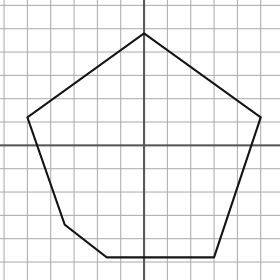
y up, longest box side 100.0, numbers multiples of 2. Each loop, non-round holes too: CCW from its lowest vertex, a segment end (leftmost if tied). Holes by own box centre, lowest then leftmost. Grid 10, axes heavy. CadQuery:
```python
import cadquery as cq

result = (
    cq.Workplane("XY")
    .moveTo(-16.0, -48.0)
    .lineTo(30.0, -48.0)
    .lineTo(50.0, 12.0)
    .lineTo(0.0, 48.0)
    .lineTo(-50.0, 12.0)
    .lineTo(-34.0, -34.0)
    .close()
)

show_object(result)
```